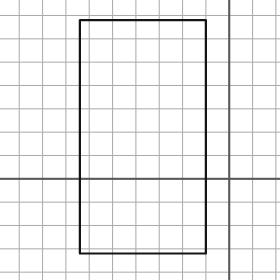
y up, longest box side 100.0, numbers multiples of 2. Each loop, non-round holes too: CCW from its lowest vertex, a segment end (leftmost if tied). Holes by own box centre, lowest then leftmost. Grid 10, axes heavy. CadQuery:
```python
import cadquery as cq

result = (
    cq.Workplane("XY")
    .moveTo(-64.0, -32.0)
    .lineTo(-10.0, -32.0)
    .lineTo(-10.0, 68.0)
    .lineTo(-64.0, 68.0)
    .close()
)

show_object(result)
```